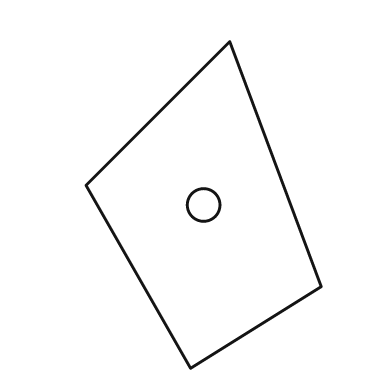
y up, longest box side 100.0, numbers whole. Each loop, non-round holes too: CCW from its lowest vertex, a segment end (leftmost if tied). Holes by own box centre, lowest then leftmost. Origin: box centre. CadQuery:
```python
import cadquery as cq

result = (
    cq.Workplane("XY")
    .moveTo(-4.0, -50.0)
    .lineTo(36.0, -25.0)
    .lineTo(8.0, 50.0)
    .lineTo(-36.0, 6.0)
    .close()
    .moveTo(0.0, 0.0)
    .circle(5.0)
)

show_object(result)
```